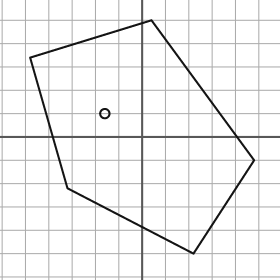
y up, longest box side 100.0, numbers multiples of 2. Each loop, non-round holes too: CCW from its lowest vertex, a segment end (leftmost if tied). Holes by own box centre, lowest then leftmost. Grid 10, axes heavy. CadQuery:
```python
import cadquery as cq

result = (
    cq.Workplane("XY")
    .moveTo(22.0, -50.0)
    .lineTo(48.0, -10.0)
    .lineTo(4.0, 50.0)
    .lineTo(-48.0, 34.0)
    .lineTo(-32.0, -22.0)
    .close()
    .moveTo(-16.0, 10.0)
    .circle(2.0)
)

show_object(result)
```